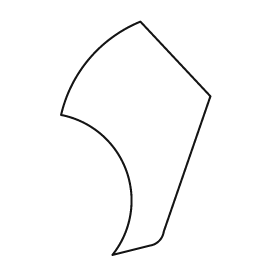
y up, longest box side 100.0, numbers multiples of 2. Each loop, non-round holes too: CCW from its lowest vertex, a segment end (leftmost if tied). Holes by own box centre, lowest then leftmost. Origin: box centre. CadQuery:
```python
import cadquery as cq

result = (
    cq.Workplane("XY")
    .moveTo(-10.0, -50.0)
    .lineTo(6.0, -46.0)
    .threePointArc((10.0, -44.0), (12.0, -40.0))
    .lineTo(32.0, 18.0)
    .lineTo(2.0, 50.0)
    .threePointArc((-20.0, 34.0), (-32.0, 10.0))
    .threePointArc((-4.0, -14.0), (-10.0, -50.0))
    .close()
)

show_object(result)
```